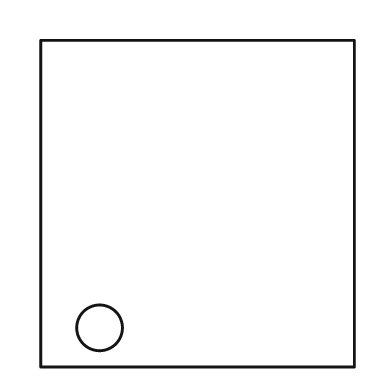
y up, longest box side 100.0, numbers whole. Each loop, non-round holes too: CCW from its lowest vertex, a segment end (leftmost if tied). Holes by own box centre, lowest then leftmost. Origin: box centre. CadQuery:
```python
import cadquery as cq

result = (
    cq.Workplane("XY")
    .moveTo(-48.0, -50.0)
    .lineTo(48.0, -50.0)
    .lineTo(48.0, 50.0)
    .lineTo(-48.0, 50.0)
    .close()
    .moveTo(-30.0, -38.0)
    .circle(7.0)
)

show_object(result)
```